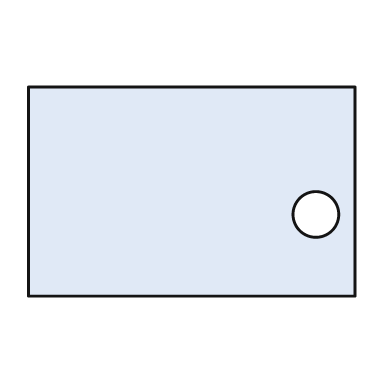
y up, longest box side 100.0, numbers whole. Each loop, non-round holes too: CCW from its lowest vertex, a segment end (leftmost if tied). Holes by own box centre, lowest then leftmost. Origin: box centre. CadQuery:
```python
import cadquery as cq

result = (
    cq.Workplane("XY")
    .moveTo(-50.0, -32.0)
    .lineTo(50.0, -32.0)
    .lineTo(50.0, 32.0)
    .lineTo(-50.0, 32.0)
    .close()
    .moveTo(38.0, -7.0)
    .circle(7.0)
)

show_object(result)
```